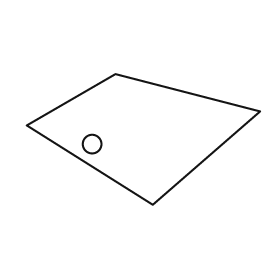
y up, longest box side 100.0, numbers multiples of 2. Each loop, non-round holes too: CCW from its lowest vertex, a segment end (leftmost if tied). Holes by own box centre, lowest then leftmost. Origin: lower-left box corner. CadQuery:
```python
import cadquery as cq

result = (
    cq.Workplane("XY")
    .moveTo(54.0, 0.0)
    .lineTo(100.0, 40.0)
    .lineTo(38.0, 56.0)
    .lineTo(0.0, 34.0)
    .close()
    .moveTo(28.0, 26.0)
    .circle(4.0)
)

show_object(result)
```